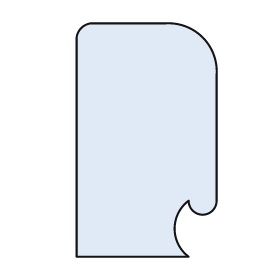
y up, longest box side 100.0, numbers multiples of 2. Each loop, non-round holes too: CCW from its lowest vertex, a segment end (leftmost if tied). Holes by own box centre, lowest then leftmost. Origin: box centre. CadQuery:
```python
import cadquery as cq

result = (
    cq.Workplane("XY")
    .moveTo(-30.0, -50.0)
    .lineTo(18.0, -50.0)
    .threePointArc((12.0, -38.0), (18.0, -26.0))
    .threePointArc((24.0, -32.0), (30.0, -26.0))
    .lineTo(30.0, 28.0)
    .threePointArc((24.0, 44.0), (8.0, 50.0))
    .lineTo(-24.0, 50.0)
    .threePointArc((-28.0, 48.0), (-30.0, 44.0))
    .close()
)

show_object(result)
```